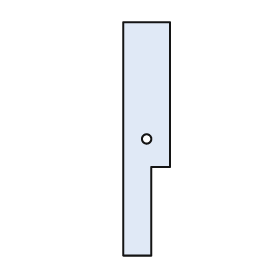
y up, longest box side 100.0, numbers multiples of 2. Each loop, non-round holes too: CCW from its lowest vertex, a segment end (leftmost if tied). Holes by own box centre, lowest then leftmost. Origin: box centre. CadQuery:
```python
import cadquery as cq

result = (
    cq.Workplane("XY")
    .moveTo(-10.0, -50.0)
    .lineTo(2.0, -50.0)
    .lineTo(2.0, -12.0)
    .lineTo(10.0, -12.0)
    .lineTo(10.0, 50.0)
    .lineTo(-10.0, 50.0)
    .close()
    .moveTo(0.0, 0.0)
    .circle(2.0)
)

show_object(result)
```